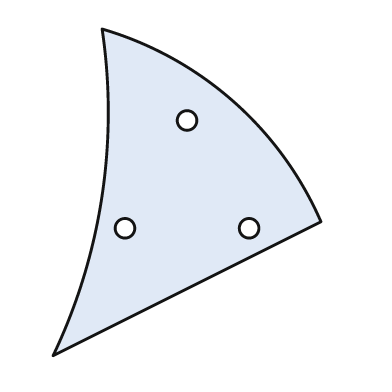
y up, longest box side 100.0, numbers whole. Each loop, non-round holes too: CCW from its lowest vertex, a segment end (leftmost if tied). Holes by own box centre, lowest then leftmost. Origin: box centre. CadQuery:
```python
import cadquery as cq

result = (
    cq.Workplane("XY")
    .moveTo(-41.0, -50.0)
    .lineTo(41.0, -9.0)
    .threePointArc((14.0, 28.0), (-26.0, 50.0))
    .threePointArc((-26.0, -1.0), (-41.0, -50.0))
    .close()
    .moveTo(-19.0, -11.0)
    .circle(3.0)
    .moveTo(19.0, -11.0)
    .circle(3.0)
    .moveTo(0.0, 22.0)
    .circle(3.0)
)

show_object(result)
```